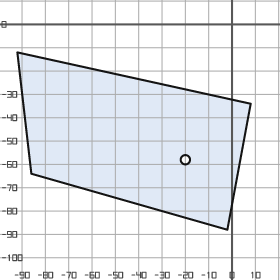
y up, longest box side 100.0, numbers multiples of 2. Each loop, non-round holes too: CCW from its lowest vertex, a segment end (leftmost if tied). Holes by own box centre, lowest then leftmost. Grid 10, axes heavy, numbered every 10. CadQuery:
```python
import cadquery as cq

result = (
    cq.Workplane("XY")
    .moveTo(-2.0, -88.0)
    .lineTo(8.0, -34.0)
    .lineTo(-92.0, -12.0)
    .lineTo(-86.0, -64.0)
    .close()
    .moveTo(-20.0, -58.0)
    .circle(2.0)
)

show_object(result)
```